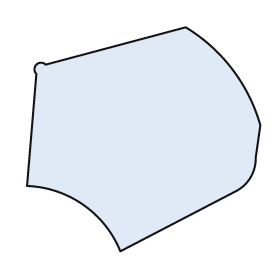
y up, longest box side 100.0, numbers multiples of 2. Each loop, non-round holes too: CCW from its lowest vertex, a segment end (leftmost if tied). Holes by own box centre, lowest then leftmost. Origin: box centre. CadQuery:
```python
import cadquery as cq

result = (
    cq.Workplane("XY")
    .moveTo(-10.0, -48.0)
    .lineTo(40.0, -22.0)
    .threePointArc((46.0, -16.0), (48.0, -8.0))
    .lineTo(50.0, 6.0)
    .threePointArc((38.0, 30.0), (18.0, 48.0))
    .lineTo(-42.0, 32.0)
    .threePointArc((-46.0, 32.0), (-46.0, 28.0))
    .lineTo(-50.0, -20.0)
    .threePointArc((-26.0, -28.0), (-10.0, -48.0))
    .close()
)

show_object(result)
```